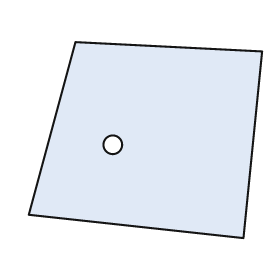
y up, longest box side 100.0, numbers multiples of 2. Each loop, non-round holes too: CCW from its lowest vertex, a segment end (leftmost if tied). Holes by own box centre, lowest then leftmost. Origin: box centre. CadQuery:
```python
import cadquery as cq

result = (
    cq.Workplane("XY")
    .moveTo(42.0, -42.0)
    .lineTo(50.0, 38.0)
    .lineTo(-30.0, 42.0)
    .lineTo(-50.0, -32.0)
    .close()
    .moveTo(-14.0, -2.0)
    .circle(4.0)
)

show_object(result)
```